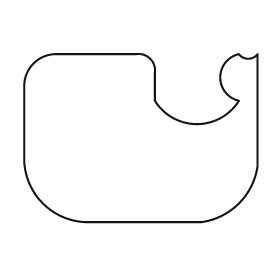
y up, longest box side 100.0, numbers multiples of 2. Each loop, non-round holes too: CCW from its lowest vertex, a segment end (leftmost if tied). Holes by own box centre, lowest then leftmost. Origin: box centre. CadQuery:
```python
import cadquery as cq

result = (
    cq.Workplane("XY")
    .moveTo(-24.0, -36.0)
    .lineTo(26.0, -36.0)
    .threePointArc((42.0, -28.0), (50.0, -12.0))
    .lineTo(50.0, 36.0)
    .threePointArc((46.0, 34.0), (42.0, 36.0))
    .threePointArc((34.0, 26.0), (42.0, 16.0))
    .threePointArc((24.0, 6.0), (6.0, 16.0))
    .lineTo(6.0, 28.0)
    .threePointArc((4.0, 34.0), (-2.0, 36.0))
    .lineTo(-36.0, 36.0)
    .threePointArc((-46.0, 32.0), (-50.0, 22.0))
    .lineTo(-50.0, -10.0)
    .threePointArc((-42.0, -28.0), (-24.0, -36.0))
    .close()
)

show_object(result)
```